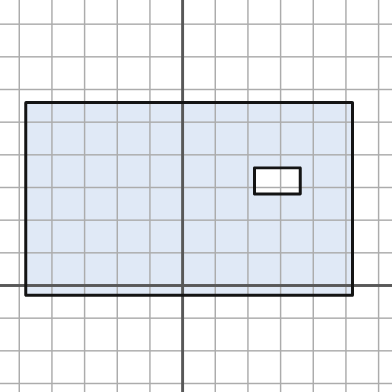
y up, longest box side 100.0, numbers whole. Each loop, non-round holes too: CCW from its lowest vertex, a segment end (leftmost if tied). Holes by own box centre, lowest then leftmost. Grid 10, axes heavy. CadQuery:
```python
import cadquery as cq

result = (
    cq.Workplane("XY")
    .moveTo(-48.0, -3.0)
    .lineTo(52.0, -3.0)
    .lineTo(52.0, 56.0)
    .lineTo(-48.0, 56.0)
    .close()
    .moveTo(22.0, 28.0)
    .lineTo(36.0, 28.0)
    .lineTo(36.0, 36.0)
    .lineTo(22.0, 36.0)
    .close()
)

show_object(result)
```